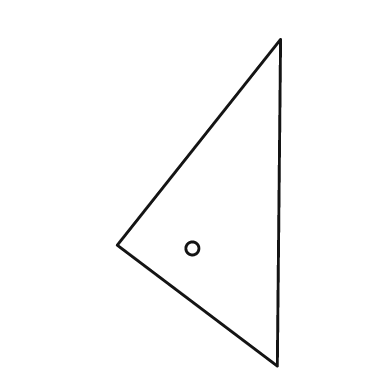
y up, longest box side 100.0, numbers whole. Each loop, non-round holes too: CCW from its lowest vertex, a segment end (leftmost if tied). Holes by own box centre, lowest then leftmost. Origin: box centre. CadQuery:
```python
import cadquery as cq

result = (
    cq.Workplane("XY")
    .moveTo(24.0, -50.0)
    .lineTo(25.0, 50.0)
    .lineTo(-25.0, -13.0)
    .close()
    .moveTo(-2.0, -14.0)
    .circle(2.0)
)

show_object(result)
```